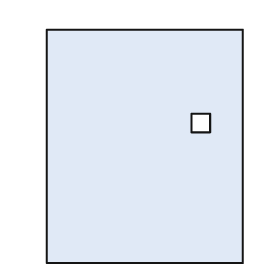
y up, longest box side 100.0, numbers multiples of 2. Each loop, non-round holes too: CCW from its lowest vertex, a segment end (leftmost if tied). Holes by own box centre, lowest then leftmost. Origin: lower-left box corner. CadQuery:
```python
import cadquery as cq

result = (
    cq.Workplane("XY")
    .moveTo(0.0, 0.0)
    .lineTo(84.0, 0.0)
    .lineTo(84.0, 100.0)
    .lineTo(0.0, 100.0)
    .close()
    .moveTo(62.0, 56.0)
    .lineTo(70.0, 56.0)
    .lineTo(70.0, 64.0)
    .lineTo(62.0, 64.0)
    .close()
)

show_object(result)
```